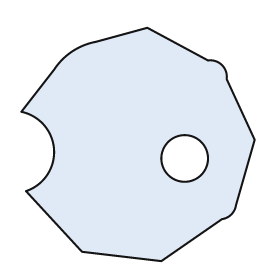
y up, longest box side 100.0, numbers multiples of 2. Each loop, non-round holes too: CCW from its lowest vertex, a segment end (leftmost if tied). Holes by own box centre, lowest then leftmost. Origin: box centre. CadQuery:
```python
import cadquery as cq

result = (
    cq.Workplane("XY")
    .moveTo(10.0, -50.0)
    .lineTo(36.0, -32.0)
    .threePointArc((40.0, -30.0), (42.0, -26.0))
    .lineTo(50.0, 2.0)
    .lineTo(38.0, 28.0)
    .threePointArc((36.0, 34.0), (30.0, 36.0))
    .lineTo(4.0, 50.0)
    .lineTo(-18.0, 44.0)
    .threePointArc((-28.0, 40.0), (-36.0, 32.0))
    .lineTo(-50.0, 14.0)
    .threePointArc((-36.0, -2.0), (-48.0, -20.0))
    .lineTo(-24.0, -46.0)
    .close()
    .moveTo(20.0, -6.0)
    .circle(10.0)
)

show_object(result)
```